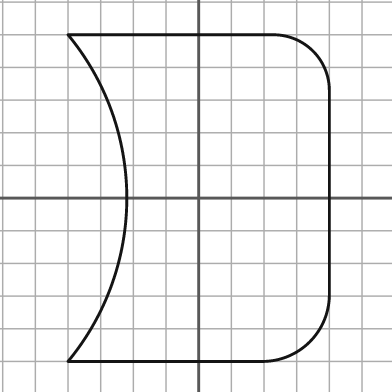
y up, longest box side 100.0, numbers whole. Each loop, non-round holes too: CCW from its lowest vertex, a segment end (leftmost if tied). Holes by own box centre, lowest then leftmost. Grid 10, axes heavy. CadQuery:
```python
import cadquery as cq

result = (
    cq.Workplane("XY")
    .moveTo(-40.0, -50.0)
    .lineTo(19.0, -50.0)
    .threePointArc((34.0, -44.0), (40.0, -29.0))
    .lineTo(40.0, 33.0)
    .threePointArc((35.0, 45.0), (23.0, 50.0))
    .lineTo(-40.0, 50.0)
    .threePointArc((-22.0, 0.0), (-40.0, -50.0))
    .close()
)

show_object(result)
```